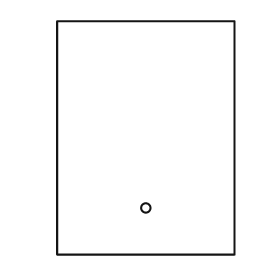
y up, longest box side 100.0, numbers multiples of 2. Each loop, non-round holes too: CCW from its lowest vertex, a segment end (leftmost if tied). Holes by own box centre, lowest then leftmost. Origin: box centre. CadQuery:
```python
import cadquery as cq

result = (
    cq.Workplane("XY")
    .moveTo(-38.0, -50.0)
    .lineTo(38.0, -50.0)
    .lineTo(38.0, 50.0)
    .lineTo(-38.0, 50.0)
    .close()
    .moveTo(0.0, -30.0)
    .circle(2.0)
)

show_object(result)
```